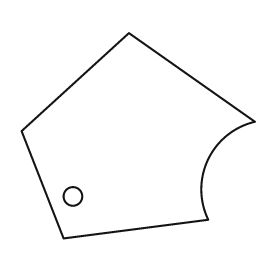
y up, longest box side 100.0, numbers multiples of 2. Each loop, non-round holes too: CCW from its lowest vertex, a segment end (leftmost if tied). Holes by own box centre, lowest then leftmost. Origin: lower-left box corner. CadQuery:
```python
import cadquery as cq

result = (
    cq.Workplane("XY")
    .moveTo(18.0, 0.0)
    .lineTo(80.0, 8.0)
    .threePointArc((80.0, 34.0), (100.0, 50.0))
    .lineTo(46.0, 88.0)
    .lineTo(0.0, 46.0)
    .close()
    .moveTo(22.0, 18.0)
    .circle(4.0)
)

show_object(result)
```